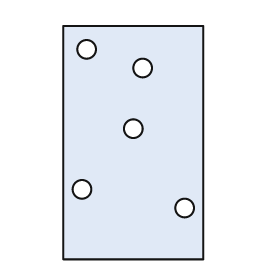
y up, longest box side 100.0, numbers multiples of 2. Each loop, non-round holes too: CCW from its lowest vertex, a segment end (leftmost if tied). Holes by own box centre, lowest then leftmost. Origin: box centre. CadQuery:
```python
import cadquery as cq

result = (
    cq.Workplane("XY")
    .moveTo(-30.0, -50.0)
    .lineTo(30.0, -50.0)
    .lineTo(30.0, 50.0)
    .lineTo(-30.0, 50.0)
    .close()
    .moveTo(22.0, -28.0)
    .circle(4.0)
    .moveTo(-22.0, -20.0)
    .circle(4.0)
    .moveTo(0.0, 6.0)
    .circle(4.0)
    .moveTo(4.0, 32.0)
    .circle(4.0)
    .moveTo(-20.0, 40.0)
    .circle(4.0)
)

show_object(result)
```